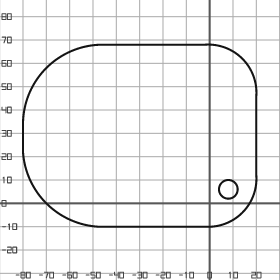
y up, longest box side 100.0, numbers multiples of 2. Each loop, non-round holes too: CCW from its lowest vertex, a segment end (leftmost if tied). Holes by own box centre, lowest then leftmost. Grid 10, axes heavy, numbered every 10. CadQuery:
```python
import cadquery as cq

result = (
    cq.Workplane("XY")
    .moveTo(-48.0, -10.0)
    .lineTo(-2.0, -10.0)
    .threePointArc((14.0, -4.0), (20.0, 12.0))
    .lineTo(20.0, 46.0)
    .threePointArc((14.0, 62.0), (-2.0, 68.0))
    .lineTo(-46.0, 68.0)
    .threePointArc((-70.0, 58.0), (-80.0, 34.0))
    .lineTo(-80.0, 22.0)
    .threePointArc((-70.0, 0.0), (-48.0, -10.0))
    .close()
    .moveTo(8.0, 6.0)
    .circle(4.0)
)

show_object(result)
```